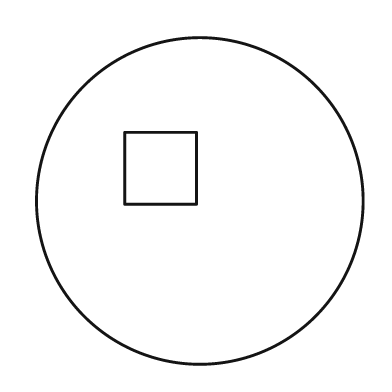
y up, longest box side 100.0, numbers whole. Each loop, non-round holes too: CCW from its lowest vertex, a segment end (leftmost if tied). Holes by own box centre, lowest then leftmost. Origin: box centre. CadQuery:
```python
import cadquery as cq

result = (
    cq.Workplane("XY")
    .moveTo(0.0, 0.0)
    .circle(50.0)
    .moveTo(-23.0, -1.0)
    .lineTo(-1.0, -1.0)
    .lineTo(-1.0, 21.0)
    .lineTo(-23.0, 21.0)
    .close()
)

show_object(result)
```